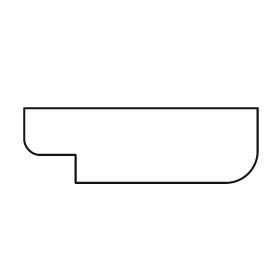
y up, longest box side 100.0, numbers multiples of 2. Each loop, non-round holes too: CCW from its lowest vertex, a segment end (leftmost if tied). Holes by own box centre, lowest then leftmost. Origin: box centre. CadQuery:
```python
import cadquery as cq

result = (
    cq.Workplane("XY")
    .moveTo(-28.0, -16.0)
    .lineTo(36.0, -16.0)
    .threePointArc((46.0, -12.0), (50.0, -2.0))
    .lineTo(50.0, 16.0)
    .lineTo(-50.0, 16.0)
    .lineTo(-50.0, 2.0)
    .threePointArc((-48.0, -2.0), (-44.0, -4.0))
    .lineTo(-28.0, -4.0)
    .close()
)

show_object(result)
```